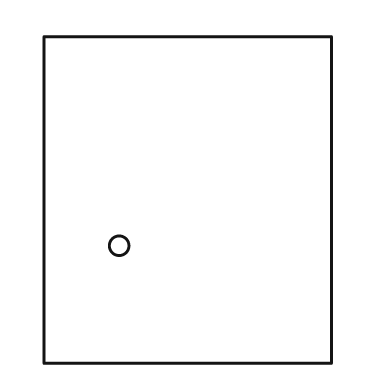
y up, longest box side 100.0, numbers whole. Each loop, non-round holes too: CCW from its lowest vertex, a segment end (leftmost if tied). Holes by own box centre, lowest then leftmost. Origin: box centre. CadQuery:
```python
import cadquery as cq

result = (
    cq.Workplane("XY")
    .moveTo(-44.0, -50.0)
    .lineTo(44.0, -50.0)
    .lineTo(44.0, 50.0)
    .lineTo(-44.0, 50.0)
    .close()
    .moveTo(-21.0, -14.0)
    .circle(3.0)
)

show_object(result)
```